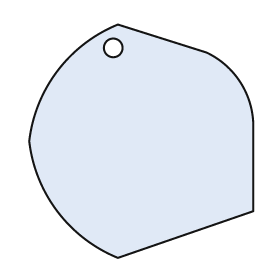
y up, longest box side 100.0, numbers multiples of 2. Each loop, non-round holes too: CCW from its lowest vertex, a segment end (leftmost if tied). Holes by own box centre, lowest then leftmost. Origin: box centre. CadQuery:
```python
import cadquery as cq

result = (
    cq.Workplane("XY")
    .moveTo(-10.0, -50.0)
    .lineTo(48.0, -30.0)
    .lineTo(48.0, 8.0)
    .threePointArc((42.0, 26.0), (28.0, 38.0))
    .lineTo(-10.0, 50.0)
    .threePointArc((-36.0, 30.0), (-48.0, 0.0))
    .threePointArc((-36.0, -30.0), (-10.0, -50.0))
    .close()
    .moveTo(-12.0, 40.0)
    .circle(4.0)
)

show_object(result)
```